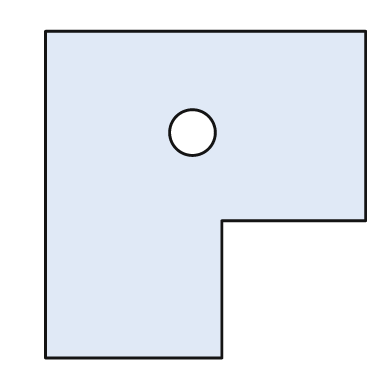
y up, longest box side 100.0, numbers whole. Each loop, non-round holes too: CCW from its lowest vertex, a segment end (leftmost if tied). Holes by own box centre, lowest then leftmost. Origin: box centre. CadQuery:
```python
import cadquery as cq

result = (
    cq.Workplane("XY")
    .moveTo(-49.0, -50.0)
    .lineTo(5.0, -50.0)
    .lineTo(5.0, -8.0)
    .lineTo(49.0, -8.0)
    .lineTo(49.0, 50.0)
    .lineTo(-49.0, 50.0)
    .close()
    .moveTo(-4.0, 19.0)
    .circle(7.0)
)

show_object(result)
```